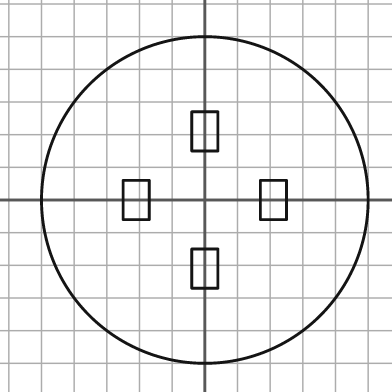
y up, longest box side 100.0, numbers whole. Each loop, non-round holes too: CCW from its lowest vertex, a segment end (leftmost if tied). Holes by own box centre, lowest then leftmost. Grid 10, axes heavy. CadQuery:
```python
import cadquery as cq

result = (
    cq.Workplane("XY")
    .moveTo(0.0, 0.0)
    .circle(50.0)
    .moveTo(-4.0, -27.0)
    .lineTo(4.0, -27.0)
    .lineTo(4.0, -15.0)
    .lineTo(-4.0, -15.0)
    .close()
    .moveTo(-25.0, -6.0)
    .lineTo(-17.0, -6.0)
    .lineTo(-17.0, 6.0)
    .lineTo(-25.0, 6.0)
    .close()
    .moveTo(17.0, -6.0)
    .lineTo(25.0, -6.0)
    .lineTo(25.0, 6.0)
    .lineTo(17.0, 6.0)
    .close()
    .moveTo(-4.0, 15.0)
    .lineTo(4.0, 15.0)
    .lineTo(4.0, 27.0)
    .lineTo(-4.0, 27.0)
    .close()
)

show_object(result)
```